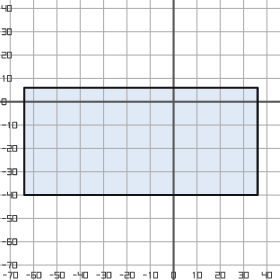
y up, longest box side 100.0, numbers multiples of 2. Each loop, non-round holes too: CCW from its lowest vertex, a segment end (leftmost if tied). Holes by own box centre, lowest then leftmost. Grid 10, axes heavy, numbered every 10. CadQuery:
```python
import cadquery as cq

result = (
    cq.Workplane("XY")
    .moveTo(-64.0, -40.0)
    .lineTo(36.0, -40.0)
    .lineTo(36.0, 6.0)
    .lineTo(-64.0, 6.0)
    .close()
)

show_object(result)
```